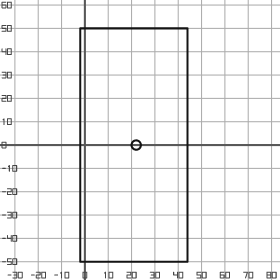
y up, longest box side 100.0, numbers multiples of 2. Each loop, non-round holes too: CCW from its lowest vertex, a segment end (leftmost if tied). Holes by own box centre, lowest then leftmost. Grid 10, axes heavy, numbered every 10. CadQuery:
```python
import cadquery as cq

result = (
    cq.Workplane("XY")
    .moveTo(-2.0, -50.0)
    .lineTo(44.0, -50.0)
    .lineTo(44.0, 50.0)
    .lineTo(-2.0, 50.0)
    .close()
    .moveTo(22.0, 0.0)
    .circle(2.0)
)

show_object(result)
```